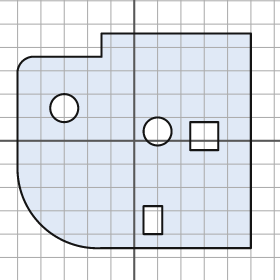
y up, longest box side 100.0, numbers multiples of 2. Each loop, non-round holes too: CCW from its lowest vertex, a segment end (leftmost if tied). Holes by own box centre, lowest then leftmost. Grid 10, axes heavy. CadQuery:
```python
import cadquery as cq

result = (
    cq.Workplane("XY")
    .moveTo(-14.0, -46.0)
    .lineTo(50.0, -46.0)
    .lineTo(50.0, 46.0)
    .lineTo(-14.0, 46.0)
    .lineTo(-14.0, 36.0)
    .lineTo(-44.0, 36.0)
    .threePointArc((-48.0, 34.0), (-50.0, 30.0))
    .lineTo(-50.0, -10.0)
    .threePointArc((-40.0, -36.0), (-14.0, -46.0))
    .close()
    .moveTo(4.0, -40.0)
    .lineTo(12.0, -40.0)
    .lineTo(12.0, -28.0)
    .lineTo(4.0, -28.0)
    .close()
    .moveTo(24.0, -4.0)
    .lineTo(36.0, -4.0)
    .lineTo(36.0, 8.0)
    .lineTo(24.0, 8.0)
    .close()
    .moveTo(10.0, 4.0)
    .circle(6.0)
    .moveTo(-30.0, 14.0)
    .circle(6.0)
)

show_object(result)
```